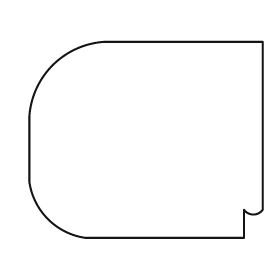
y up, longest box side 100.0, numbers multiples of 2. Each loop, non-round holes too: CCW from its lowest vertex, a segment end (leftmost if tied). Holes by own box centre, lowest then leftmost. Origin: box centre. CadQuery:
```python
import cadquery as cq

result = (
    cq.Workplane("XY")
    .moveTo(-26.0, -42.0)
    .lineTo(42.0, -42.0)
    .lineTo(42.0, -30.0)
    .threePointArc((46.0, -32.0), (50.0, -30.0))
    .lineTo(50.0, 42.0)
    .lineTo(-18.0, 42.0)
    .threePointArc((-40.0, 32.0), (-50.0, 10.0))
    .lineTo(-50.0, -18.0)
    .threePointArc((-42.0, -34.0), (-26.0, -42.0))
    .close()
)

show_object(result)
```